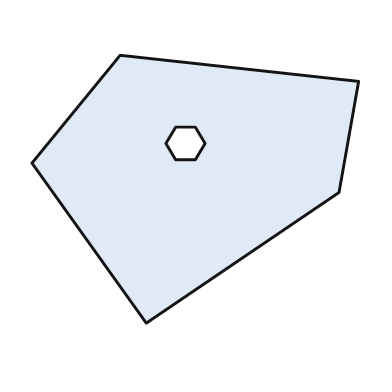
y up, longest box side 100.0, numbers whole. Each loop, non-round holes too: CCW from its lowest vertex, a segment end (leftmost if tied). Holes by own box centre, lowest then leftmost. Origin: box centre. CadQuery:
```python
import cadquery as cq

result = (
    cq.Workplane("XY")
    .moveTo(-15.0, -41.0)
    .lineTo(44.0, -1.0)
    .lineTo(50.0, 33.0)
    .lineTo(-23.0, 41.0)
    .lineTo(-50.0, 8.0)
    .close()
    .moveTo(-6.0, 9.0)
    .lineTo(0.0, 9.0)
    .lineTo(3.0, 14.0)
    .lineTo(0.0, 19.0)
    .lineTo(-6.0, 19.0)
    .lineTo(-9.0, 14.0)
    .close()
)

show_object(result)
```